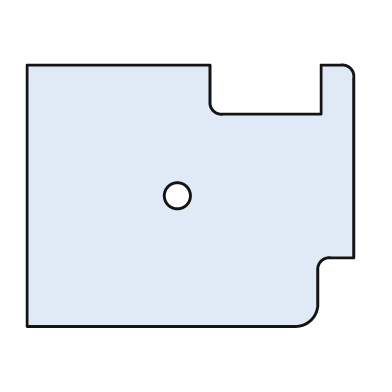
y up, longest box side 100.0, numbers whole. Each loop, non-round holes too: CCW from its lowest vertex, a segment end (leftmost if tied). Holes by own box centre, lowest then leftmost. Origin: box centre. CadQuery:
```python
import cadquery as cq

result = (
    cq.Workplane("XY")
    .moveTo(-50.0, -40.0)
    .lineTo(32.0, -40.0)
    .threePointArc((37.0, -38.0), (39.0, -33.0))
    .lineTo(39.0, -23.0)
    .threePointArc((40.0, -20.0), (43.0, -19.0))
    .lineTo(50.0, -19.0)
    .lineTo(50.0, 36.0)
    .threePointArc((49.0, 39.0), (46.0, 40.0))
    .lineTo(40.0, 40.0)
    .lineTo(40.0, 25.0)
    .lineTo(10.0, 25.0)
    .threePointArc((7.0, 26.0), (6.0, 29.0))
    .lineTo(6.0, 40.0)
    .lineTo(-50.0, 40.0)
    .close()
    .moveTo(-4.0, 0.0)
    .circle(4.0)
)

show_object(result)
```